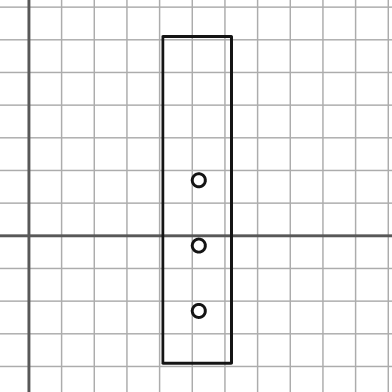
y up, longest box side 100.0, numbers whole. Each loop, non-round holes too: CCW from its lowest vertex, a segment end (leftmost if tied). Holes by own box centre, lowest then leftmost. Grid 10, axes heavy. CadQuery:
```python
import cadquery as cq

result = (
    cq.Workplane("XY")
    .moveTo(41.0, -39.0)
    .lineTo(62.0, -39.0)
    .lineTo(62.0, 61.0)
    .lineTo(41.0, 61.0)
    .close()
    .moveTo(52.0, -23.0)
    .circle(2.0)
    .moveTo(52.0, -3.0)
    .circle(2.0)
    .moveTo(52.0, 17.0)
    .circle(2.0)
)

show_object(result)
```